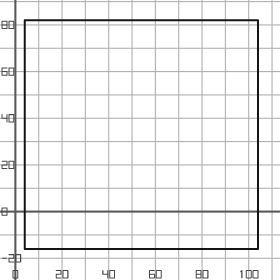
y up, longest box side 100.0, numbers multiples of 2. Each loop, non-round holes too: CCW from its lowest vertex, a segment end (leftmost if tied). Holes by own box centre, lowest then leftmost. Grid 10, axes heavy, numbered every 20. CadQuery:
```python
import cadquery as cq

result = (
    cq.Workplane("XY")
    .moveTo(4.0, -16.0)
    .lineTo(104.0, -16.0)
    .lineTo(104.0, 82.0)
    .lineTo(4.0, 82.0)
    .close()
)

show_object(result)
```